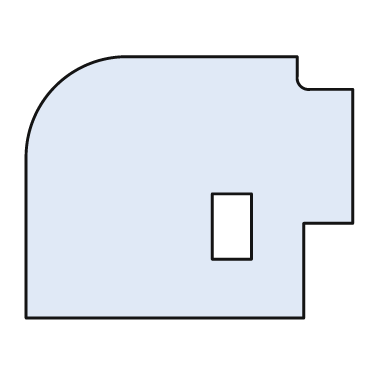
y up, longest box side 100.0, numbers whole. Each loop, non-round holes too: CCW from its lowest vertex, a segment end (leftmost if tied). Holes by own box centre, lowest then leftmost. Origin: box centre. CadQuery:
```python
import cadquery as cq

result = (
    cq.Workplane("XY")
    .moveTo(-50.0, -40.0)
    .lineTo(35.0, -40.0)
    .lineTo(35.0, -11.0)
    .lineTo(50.0, -11.0)
    .lineTo(50.0, 30.0)
    .lineTo(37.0, 30.0)
    .threePointArc((34.0, 31.0), (33.0, 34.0))
    .lineTo(33.0, 40.0)
    .lineTo(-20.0, 40.0)
    .threePointArc((-41.0, 31.0), (-50.0, 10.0))
    .close()
    .moveTo(7.0, -22.0)
    .lineTo(19.0, -22.0)
    .lineTo(19.0, -2.0)
    .lineTo(7.0, -2.0)
    .close()
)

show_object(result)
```